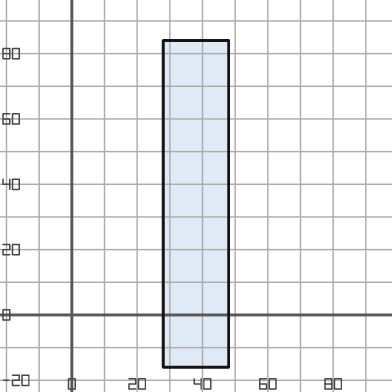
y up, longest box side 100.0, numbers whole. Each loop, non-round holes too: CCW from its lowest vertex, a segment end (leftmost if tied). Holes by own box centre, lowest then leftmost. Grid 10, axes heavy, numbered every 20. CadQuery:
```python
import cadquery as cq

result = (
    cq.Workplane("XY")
    .moveTo(28.0, -16.0)
    .lineTo(48.0, -16.0)
    .lineTo(48.0, 84.0)
    .lineTo(28.0, 84.0)
    .close()
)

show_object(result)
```